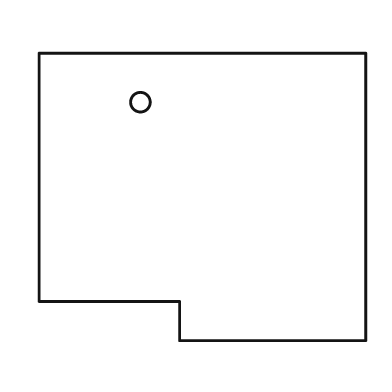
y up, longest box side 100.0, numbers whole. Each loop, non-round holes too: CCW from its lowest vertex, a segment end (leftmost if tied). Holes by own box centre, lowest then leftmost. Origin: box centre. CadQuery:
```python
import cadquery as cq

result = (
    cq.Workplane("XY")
    .moveTo(-7.0, -44.0)
    .lineTo(50.0, -44.0)
    .lineTo(50.0, 44.0)
    .lineTo(-50.0, 44.0)
    .lineTo(-50.0, -32.0)
    .lineTo(-7.0, -32.0)
    .close()
    .moveTo(-19.0, 29.0)
    .circle(3.0)
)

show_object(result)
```